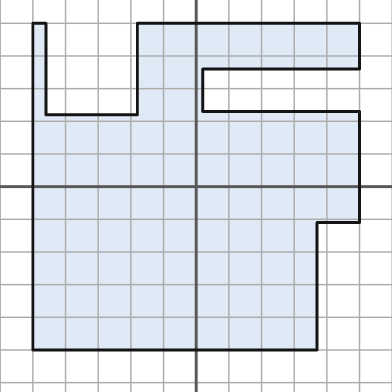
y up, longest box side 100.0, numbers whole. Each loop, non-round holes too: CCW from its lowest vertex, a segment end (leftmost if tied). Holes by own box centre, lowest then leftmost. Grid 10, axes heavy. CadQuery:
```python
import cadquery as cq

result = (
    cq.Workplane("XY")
    .moveTo(-50.0, -50.0)
    .lineTo(37.0, -50.0)
    .lineTo(37.0, -11.0)
    .lineTo(50.0, -11.0)
    .lineTo(50.0, 23.0)
    .lineTo(2.0, 23.0)
    .lineTo(2.0, 36.0)
    .lineTo(50.0, 36.0)
    .lineTo(50.0, 50.0)
    .lineTo(-18.0, 50.0)
    .lineTo(-18.0, 22.0)
    .lineTo(-46.0, 22.0)
    .lineTo(-46.0, 50.0)
    .lineTo(-50.0, 50.0)
    .close()
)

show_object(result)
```